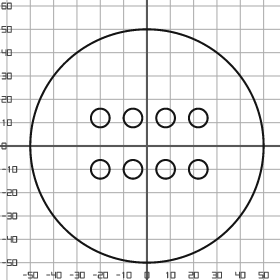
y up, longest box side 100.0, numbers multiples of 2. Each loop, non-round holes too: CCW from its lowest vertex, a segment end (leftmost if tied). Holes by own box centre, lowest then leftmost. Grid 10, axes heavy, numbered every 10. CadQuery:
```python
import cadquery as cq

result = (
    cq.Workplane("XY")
    .moveTo(0.0, 0.0)
    .circle(50.0)
    .moveTo(-20.0, -10.0)
    .circle(4.0)
    .moveTo(-6.0, -10.0)
    .circle(4.0)
    .moveTo(8.0, -10.0)
    .circle(4.0)
    .moveTo(22.0, -10.0)
    .circle(4.0)
    .moveTo(-20.0, 12.0)
    .circle(4.0)
    .moveTo(-6.0, 12.0)
    .circle(4.0)
    .moveTo(8.0, 12.0)
    .circle(4.0)
    .moveTo(22.0, 12.0)
    .circle(4.0)
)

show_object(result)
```